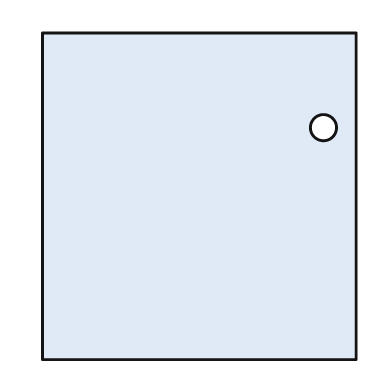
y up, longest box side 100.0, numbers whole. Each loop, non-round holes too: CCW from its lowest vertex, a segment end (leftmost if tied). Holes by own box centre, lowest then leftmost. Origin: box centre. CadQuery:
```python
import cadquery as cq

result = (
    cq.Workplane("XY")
    .moveTo(-48.0, -50.0)
    .lineTo(48.0, -50.0)
    .lineTo(48.0, 50.0)
    .lineTo(-48.0, 50.0)
    .close()
    .moveTo(38.0, 21.0)
    .circle(4.0)
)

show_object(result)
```